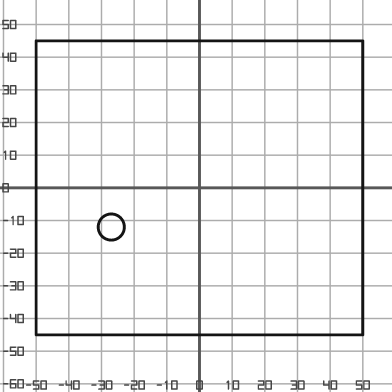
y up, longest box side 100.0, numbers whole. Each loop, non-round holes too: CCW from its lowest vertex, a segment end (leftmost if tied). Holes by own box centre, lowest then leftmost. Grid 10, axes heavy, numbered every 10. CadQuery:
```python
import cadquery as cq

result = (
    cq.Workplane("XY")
    .moveTo(-50.0, -45.0)
    .lineTo(50.0, -45.0)
    .lineTo(50.0, 45.0)
    .lineTo(-50.0, 45.0)
    .close()
    .moveTo(-27.0, -12.0)
    .circle(4.0)
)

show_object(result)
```